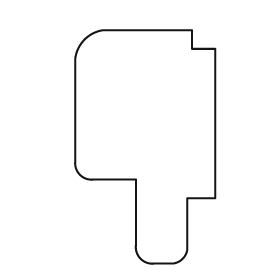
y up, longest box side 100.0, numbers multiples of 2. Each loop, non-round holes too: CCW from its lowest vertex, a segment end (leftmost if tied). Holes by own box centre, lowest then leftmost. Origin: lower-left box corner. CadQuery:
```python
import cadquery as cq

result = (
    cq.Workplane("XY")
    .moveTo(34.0, 0.0)
    .lineTo(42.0, 0.0)
    .threePointArc((46.0, 2.0), (48.0, 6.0))
    .lineTo(48.0, 28.0)
    .lineTo(60.0, 28.0)
    .lineTo(60.0, 92.0)
    .lineTo(50.0, 92.0)
    .lineTo(50.0, 100.0)
    .lineTo(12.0, 100.0)
    .threePointArc((4.0, 96.0), (0.0, 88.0))
    .lineTo(0.0, 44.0)
    .threePointArc((2.0, 38.0), (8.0, 36.0))
    .lineTo(26.0, 36.0)
    .lineTo(26.0, 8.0)
    .threePointArc((28.0, 2.0), (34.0, 0.0))
    .close()
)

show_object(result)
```